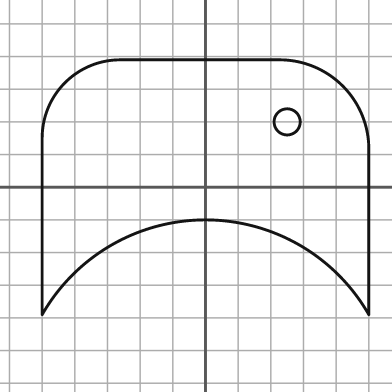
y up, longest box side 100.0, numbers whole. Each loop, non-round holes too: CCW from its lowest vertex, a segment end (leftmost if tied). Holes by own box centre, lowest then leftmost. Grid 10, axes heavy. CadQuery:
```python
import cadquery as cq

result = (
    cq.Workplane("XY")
    .moveTo(-50.0, -39.0)
    .threePointArc((0.0, -10.0), (50.0, -39.0))
    .lineTo(50.0, 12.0)
    .threePointArc((42.0, 31.0), (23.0, 39.0))
    .lineTo(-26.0, 39.0)
    .threePointArc((-43.0, 32.0), (-50.0, 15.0))
    .close()
    .moveTo(25.0, 20.0)
    .circle(4.0)
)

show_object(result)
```